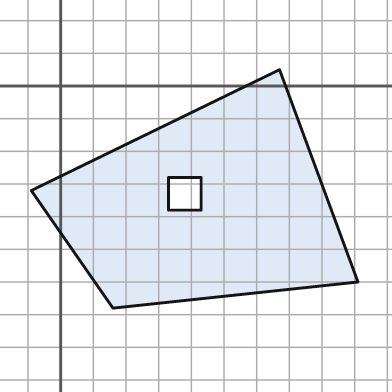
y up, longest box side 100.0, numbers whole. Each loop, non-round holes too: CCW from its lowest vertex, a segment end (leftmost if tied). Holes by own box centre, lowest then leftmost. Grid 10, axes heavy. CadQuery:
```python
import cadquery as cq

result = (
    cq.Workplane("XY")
    .moveTo(16.0, -68.0)
    .lineTo(91.0, -60.0)
    .lineTo(67.0, 5.0)
    .lineTo(-9.0, -32.0)
    .close()
    .moveTo(33.0, -38.0)
    .lineTo(43.0, -38.0)
    .lineTo(43.0, -28.0)
    .lineTo(33.0, -28.0)
    .close()
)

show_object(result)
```